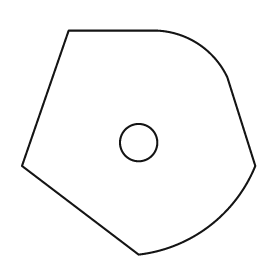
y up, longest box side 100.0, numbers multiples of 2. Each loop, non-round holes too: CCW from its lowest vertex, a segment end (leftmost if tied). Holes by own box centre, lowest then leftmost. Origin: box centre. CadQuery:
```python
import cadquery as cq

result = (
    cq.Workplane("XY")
    .moveTo(0.0, -48.0)
    .threePointArc((30.0, -36.0), (50.0, -10.0))
    .lineTo(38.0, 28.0)
    .threePointArc((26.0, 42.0), (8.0, 48.0))
    .lineTo(-30.0, 48.0)
    .lineTo(-50.0, -10.0)
    .close()
    .moveTo(0.0, 0.0)
    .circle(8.0)
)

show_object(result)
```